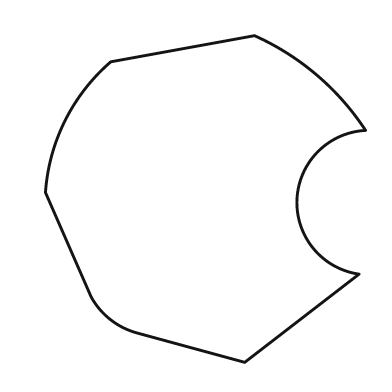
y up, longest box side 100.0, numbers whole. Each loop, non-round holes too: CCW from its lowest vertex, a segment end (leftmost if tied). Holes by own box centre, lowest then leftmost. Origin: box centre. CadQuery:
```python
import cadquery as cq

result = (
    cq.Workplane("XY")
    .moveTo(12.0, -50.0)
    .lineTo(47.0, -23.0)
    .threePointArc((28.0, 0.0), (49.0, 21.0))
    .threePointArc((34.0, 38.0), (15.0, 50.0))
    .lineTo(-29.0, 42.0)
    .threePointArc((-43.0, 24.0), (-49.0, 2.0))
    .lineTo(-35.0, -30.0)
    .threePointArc((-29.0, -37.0), (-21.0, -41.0))
    .close()
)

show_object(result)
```